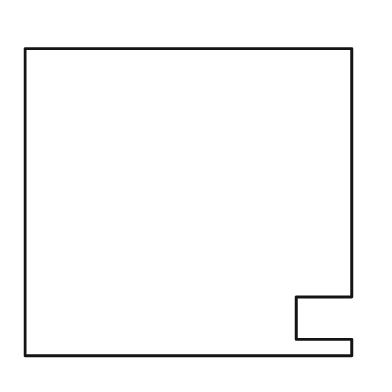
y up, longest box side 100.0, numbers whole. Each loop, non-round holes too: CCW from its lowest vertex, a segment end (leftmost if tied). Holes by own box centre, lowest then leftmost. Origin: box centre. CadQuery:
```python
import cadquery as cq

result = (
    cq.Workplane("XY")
    .moveTo(-50.0, -47.0)
    .lineTo(50.0, -47.0)
    .lineTo(50.0, -42.0)
    .lineTo(33.0, -42.0)
    .lineTo(33.0, -29.0)
    .lineTo(50.0, -29.0)
    .lineTo(50.0, 47.0)
    .lineTo(-50.0, 47.0)
    .close()
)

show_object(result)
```